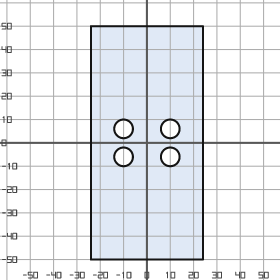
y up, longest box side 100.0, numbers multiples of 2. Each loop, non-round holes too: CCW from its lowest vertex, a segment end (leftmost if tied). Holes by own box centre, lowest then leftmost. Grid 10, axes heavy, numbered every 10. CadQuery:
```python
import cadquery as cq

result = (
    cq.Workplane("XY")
    .moveTo(-24.0, -50.0)
    .lineTo(24.0, -50.0)
    .lineTo(24.0, 50.0)
    .lineTo(-24.0, 50.0)
    .close()
    .moveTo(-10.0, -6.0)
    .circle(4.0)
    .moveTo(10.0, -6.0)
    .circle(4.0)
    .moveTo(-10.0, 6.0)
    .circle(4.0)
    .moveTo(10.0, 6.0)
    .circle(4.0)
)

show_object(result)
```